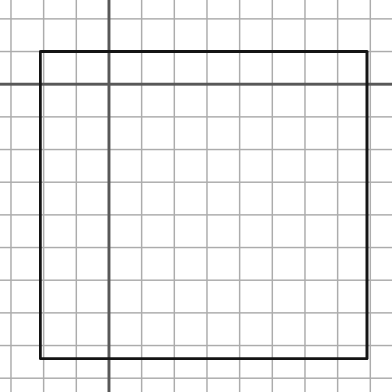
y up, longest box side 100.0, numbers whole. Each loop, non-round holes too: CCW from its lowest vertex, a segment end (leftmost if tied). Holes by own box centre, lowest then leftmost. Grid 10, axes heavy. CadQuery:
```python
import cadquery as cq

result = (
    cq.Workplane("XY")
    .moveTo(-21.0, -84.0)
    .lineTo(79.0, -84.0)
    .lineTo(79.0, 10.0)
    .lineTo(-21.0, 10.0)
    .close()
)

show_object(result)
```